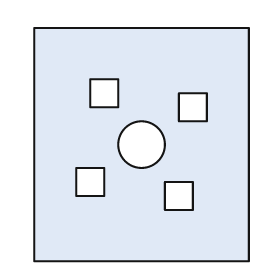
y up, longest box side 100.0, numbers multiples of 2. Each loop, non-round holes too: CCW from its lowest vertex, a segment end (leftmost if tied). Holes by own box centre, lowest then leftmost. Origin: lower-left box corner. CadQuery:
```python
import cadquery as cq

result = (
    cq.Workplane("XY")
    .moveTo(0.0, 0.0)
    .lineTo(92.0, 0.0)
    .lineTo(92.0, 100.0)
    .lineTo(0.0, 100.0)
    .close()
    .moveTo(56.0, 22.0)
    .lineTo(68.0, 22.0)
    .lineTo(68.0, 34.0)
    .lineTo(56.0, 34.0)
    .close()
    .moveTo(18.0, 28.0)
    .lineTo(30.0, 28.0)
    .lineTo(30.0, 40.0)
    .lineTo(18.0, 40.0)
    .close()
    .moveTo(46.0, 50.0)
    .circle(10.0)
    .moveTo(62.0, 60.0)
    .lineTo(74.0, 60.0)
    .lineTo(74.0, 72.0)
    .lineTo(62.0, 72.0)
    .close()
    .moveTo(24.0, 66.0)
    .lineTo(36.0, 66.0)
    .lineTo(36.0, 78.0)
    .lineTo(24.0, 78.0)
    .close()
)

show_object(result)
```